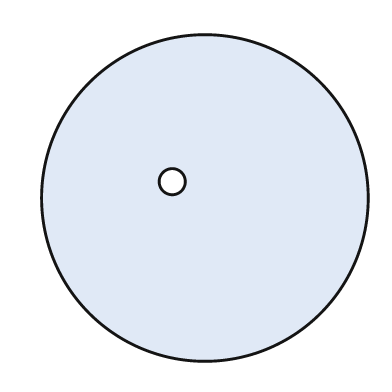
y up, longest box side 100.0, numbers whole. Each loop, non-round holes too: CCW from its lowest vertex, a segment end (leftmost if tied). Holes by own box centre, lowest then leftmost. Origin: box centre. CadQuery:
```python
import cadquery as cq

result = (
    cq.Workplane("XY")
    .moveTo(0.0, 0.0)
    .circle(50.0)
    .moveTo(-10.0, 5.0)
    .circle(4.0)
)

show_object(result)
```